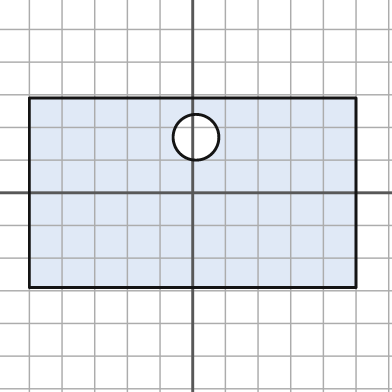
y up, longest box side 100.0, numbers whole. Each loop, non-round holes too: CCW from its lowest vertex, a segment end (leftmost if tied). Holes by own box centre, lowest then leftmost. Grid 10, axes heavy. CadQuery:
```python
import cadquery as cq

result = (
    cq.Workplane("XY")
    .moveTo(-50.0, -29.0)
    .lineTo(50.0, -29.0)
    .lineTo(50.0, 29.0)
    .lineTo(-50.0, 29.0)
    .close()
    .moveTo(1.0, 17.0)
    .circle(7.0)
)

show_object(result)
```